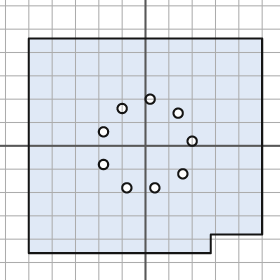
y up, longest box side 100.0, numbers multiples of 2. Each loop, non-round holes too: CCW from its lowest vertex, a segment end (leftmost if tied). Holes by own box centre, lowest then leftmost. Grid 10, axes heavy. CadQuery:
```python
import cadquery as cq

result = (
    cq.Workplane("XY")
    .moveTo(-50.0, -46.0)
    .lineTo(28.0, -46.0)
    .lineTo(28.0, -38.0)
    .lineTo(50.0, -38.0)
    .lineTo(50.0, 46.0)
    .lineTo(-50.0, 46.0)
    .close()
    .moveTo(-8.0, -18.0)
    .circle(2.0)
    .moveTo(4.0, -18.0)
    .circle(2.0)
    .moveTo(16.0, -12.0)
    .circle(2.0)
    .moveTo(-18.0, -8.0)
    .circle(2.0)
    .moveTo(20.0, 2.0)
    .circle(2.0)
    .moveTo(-18.0, 6.0)
    .circle(2.0)
    .moveTo(14.0, 14.0)
    .circle(2.0)
    .moveTo(-10.0, 16.0)
    .circle(2.0)
    .moveTo(2.0, 20.0)
    .circle(2.0)
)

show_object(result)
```